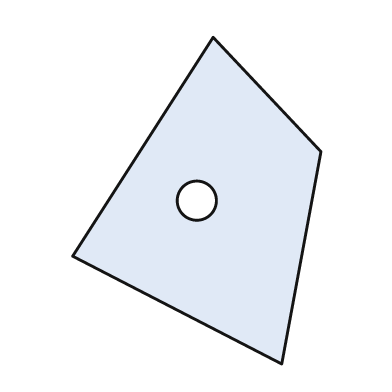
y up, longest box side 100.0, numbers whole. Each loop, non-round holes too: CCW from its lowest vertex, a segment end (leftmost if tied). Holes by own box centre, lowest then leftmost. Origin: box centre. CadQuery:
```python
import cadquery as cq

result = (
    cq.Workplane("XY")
    .moveTo(26.0, -50.0)
    .lineTo(38.0, 15.0)
    .lineTo(5.0, 50.0)
    .lineTo(-38.0, -17.0)
    .close()
    .moveTo(0.0, 0.0)
    .circle(6.0)
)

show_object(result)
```